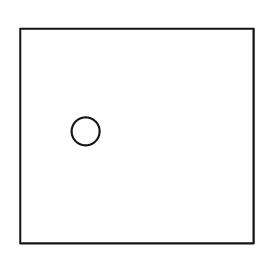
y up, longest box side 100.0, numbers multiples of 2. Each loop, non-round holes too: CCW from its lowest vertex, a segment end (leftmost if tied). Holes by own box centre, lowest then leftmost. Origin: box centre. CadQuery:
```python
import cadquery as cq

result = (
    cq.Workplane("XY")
    .moveTo(-50.0, -46.0)
    .lineTo(50.0, -46.0)
    .lineTo(50.0, 46.0)
    .lineTo(-50.0, 46.0)
    .close()
    .moveTo(-22.0, 2.0)
    .circle(6.0)
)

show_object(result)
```